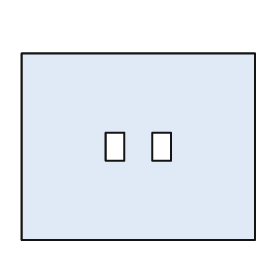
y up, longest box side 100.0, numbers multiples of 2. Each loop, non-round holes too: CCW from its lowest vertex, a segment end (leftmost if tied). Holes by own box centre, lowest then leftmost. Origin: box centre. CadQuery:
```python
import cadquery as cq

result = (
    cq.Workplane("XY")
    .moveTo(-50.0, -40.0)
    .lineTo(50.0, -40.0)
    .lineTo(50.0, 40.0)
    .lineTo(-50.0, 40.0)
    .close()
    .moveTo(-14.0, -6.0)
    .lineTo(-6.0, -6.0)
    .lineTo(-6.0, 6.0)
    .lineTo(-14.0, 6.0)
    .close()
    .moveTo(6.0, -6.0)
    .lineTo(14.0, -6.0)
    .lineTo(14.0, 6.0)
    .lineTo(6.0, 6.0)
    .close()
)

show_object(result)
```